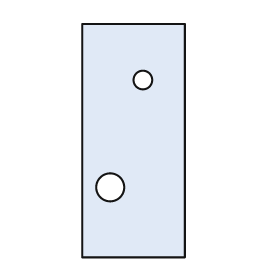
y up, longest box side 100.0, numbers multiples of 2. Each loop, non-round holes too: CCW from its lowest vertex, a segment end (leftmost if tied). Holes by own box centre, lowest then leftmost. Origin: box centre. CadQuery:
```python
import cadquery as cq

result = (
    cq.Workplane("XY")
    .moveTo(-22.0, -50.0)
    .lineTo(22.0, -50.0)
    .lineTo(22.0, 50.0)
    .lineTo(-22.0, 50.0)
    .close()
    .moveTo(-10.0, -20.0)
    .circle(6.0)
    .moveTo(4.0, 26.0)
    .circle(4.0)
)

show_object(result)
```